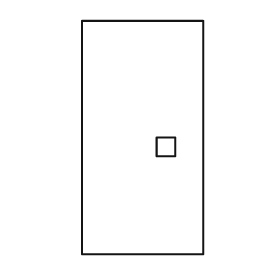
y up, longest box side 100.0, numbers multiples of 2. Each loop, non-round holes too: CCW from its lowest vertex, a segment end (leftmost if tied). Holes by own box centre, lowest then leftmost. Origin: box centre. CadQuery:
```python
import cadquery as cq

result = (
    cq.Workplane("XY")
    .moveTo(-26.0, -50.0)
    .lineTo(26.0, -50.0)
    .lineTo(26.0, 50.0)
    .lineTo(-26.0, 50.0)
    .close()
    .moveTo(6.0, -8.0)
    .lineTo(14.0, -8.0)
    .lineTo(14.0, 0.0)
    .lineTo(6.0, 0.0)
    .close()
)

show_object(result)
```